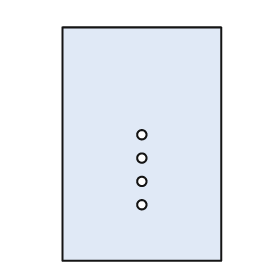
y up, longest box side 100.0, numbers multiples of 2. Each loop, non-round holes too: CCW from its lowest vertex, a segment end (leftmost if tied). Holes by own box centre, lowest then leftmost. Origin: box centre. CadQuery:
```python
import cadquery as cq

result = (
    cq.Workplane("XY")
    .moveTo(-34.0, -50.0)
    .lineTo(34.0, -50.0)
    .lineTo(34.0, 50.0)
    .lineTo(-34.0, 50.0)
    .close()
    .moveTo(0.0, -26.0)
    .circle(2.0)
    .moveTo(0.0, -16.0)
    .circle(2.0)
    .moveTo(0.0, -6.0)
    .circle(2.0)
    .moveTo(0.0, 4.0)
    .circle(2.0)
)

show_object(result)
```